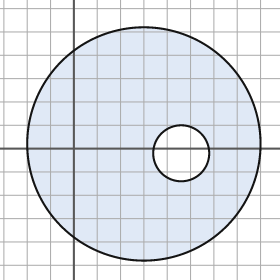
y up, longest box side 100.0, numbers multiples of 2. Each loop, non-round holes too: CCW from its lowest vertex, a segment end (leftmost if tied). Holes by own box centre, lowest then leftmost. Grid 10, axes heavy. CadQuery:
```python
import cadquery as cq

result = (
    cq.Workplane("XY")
    .moveTo(30.0, 2.0)
    .circle(50.0)
    .moveTo(46.0, -2.0)
    .circle(12.0)
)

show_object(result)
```